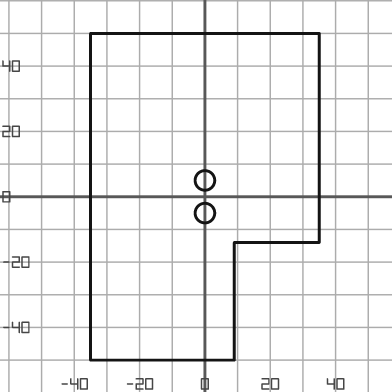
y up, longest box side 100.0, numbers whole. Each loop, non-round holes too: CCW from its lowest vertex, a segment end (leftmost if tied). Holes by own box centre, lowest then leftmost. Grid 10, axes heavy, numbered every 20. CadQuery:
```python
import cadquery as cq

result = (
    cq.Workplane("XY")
    .moveTo(-35.0, -50.0)
    .lineTo(9.0, -50.0)
    .lineTo(9.0, -14.0)
    .lineTo(35.0, -14.0)
    .lineTo(35.0, 50.0)
    .lineTo(-35.0, 50.0)
    .close()
    .moveTo(0.0, -5.0)
    .circle(3.0)
    .moveTo(0.0, 5.0)
    .circle(3.0)
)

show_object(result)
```